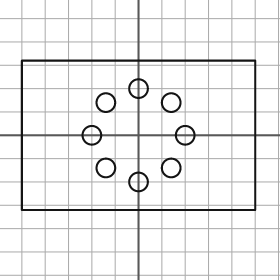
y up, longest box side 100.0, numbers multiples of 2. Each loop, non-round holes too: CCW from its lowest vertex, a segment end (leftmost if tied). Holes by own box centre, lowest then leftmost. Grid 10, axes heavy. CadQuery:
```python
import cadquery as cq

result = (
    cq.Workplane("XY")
    .moveTo(-50.0, -32.0)
    .lineTo(50.0, -32.0)
    .lineTo(50.0, 32.0)
    .lineTo(-50.0, 32.0)
    .close()
    .moveTo(0.0, -20.0)
    .circle(4.0)
    .moveTo(-14.0, -14.0)
    .circle(4.0)
    .moveTo(14.0, -14.0)
    .circle(4.0)
    .moveTo(-20.0, 0.0)
    .circle(4.0)
    .moveTo(20.0, 0.0)
    .circle(4.0)
    .moveTo(-14.0, 14.0)
    .circle(4.0)
    .moveTo(14.0, 14.0)
    .circle(4.0)
    .moveTo(0.0, 20.0)
    .circle(4.0)
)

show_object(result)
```